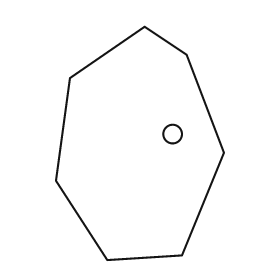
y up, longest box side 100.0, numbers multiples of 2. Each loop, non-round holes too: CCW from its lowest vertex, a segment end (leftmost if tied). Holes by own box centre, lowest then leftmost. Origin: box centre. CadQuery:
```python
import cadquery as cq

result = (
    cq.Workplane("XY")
    .moveTo(-14.0, -50.0)
    .lineTo(18.0, -48.0)
    .lineTo(36.0, -4.0)
    .lineTo(20.0, 38.0)
    .lineTo(2.0, 50.0)
    .lineTo(-30.0, 28.0)
    .lineTo(-36.0, -16.0)
    .close()
    .moveTo(14.0, 4.0)
    .circle(4.0)
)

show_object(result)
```